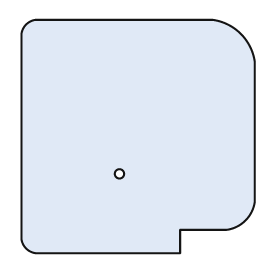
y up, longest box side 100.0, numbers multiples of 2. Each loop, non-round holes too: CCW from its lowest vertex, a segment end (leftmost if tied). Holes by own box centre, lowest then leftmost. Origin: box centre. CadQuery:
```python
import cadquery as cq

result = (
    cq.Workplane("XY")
    .moveTo(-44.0, -50.0)
    .lineTo(18.0, -50.0)
    .lineTo(18.0, -40.0)
    .lineTo(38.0, -40.0)
    .threePointArc((46.0, -36.0), (50.0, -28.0))
    .lineTo(50.0, 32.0)
    .threePointArc((44.0, 44.0), (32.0, 50.0))
    .lineTo(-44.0, 50.0)
    .threePointArc((-48.0, 48.0), (-50.0, 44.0))
    .lineTo(-50.0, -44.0)
    .threePointArc((-48.0, -48.0), (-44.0, -50.0))
    .close()
    .moveTo(-8.0, -16.0)
    .circle(2.0)
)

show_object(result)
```